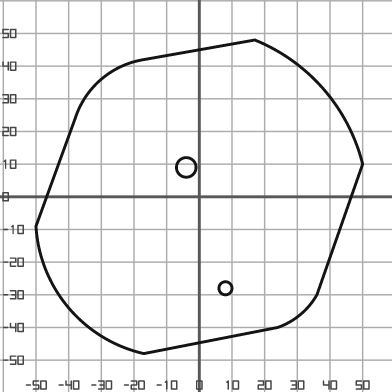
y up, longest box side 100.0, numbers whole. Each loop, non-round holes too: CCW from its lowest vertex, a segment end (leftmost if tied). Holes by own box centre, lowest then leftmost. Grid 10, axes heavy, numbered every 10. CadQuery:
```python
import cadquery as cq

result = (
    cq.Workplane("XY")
    .moveTo(-17.0, -48.0)
    .lineTo(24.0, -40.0)
    .threePointArc((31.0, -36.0), (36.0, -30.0))
    .lineTo(50.0, 10.0)
    .threePointArc((38.0, 33.0), (17.0, 48.0))
    .lineTo(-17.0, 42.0)
    .threePointArc((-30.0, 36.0), (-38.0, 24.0))
    .lineTo(-50.0, -9.0)
    .threePointArc((-40.0, -34.0), (-17.0, -48.0))
    .close()
    .moveTo(8.0, -28.0)
    .circle(2.0)
    .moveTo(-4.0, 9.0)
    .circle(3.0)
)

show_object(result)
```